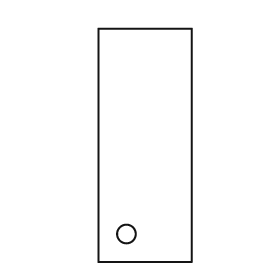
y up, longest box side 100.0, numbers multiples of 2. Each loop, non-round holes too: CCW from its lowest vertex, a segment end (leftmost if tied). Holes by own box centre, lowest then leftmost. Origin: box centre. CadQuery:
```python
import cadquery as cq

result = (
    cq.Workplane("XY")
    .moveTo(-20.0, -50.0)
    .lineTo(20.0, -50.0)
    .lineTo(20.0, 50.0)
    .lineTo(-20.0, 50.0)
    .close()
    .moveTo(-8.0, -38.0)
    .circle(4.0)
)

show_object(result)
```